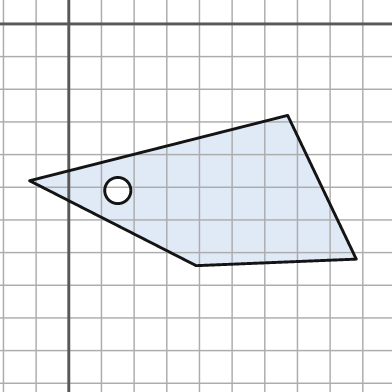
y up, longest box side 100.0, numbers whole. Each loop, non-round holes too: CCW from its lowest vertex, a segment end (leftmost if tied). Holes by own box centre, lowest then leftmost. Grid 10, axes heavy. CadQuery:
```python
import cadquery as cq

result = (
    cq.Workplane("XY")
    .moveTo(39.0, -74.0)
    .lineTo(88.0, -72.0)
    .lineTo(67.0, -28.0)
    .lineTo(-12.0, -48.0)
    .close()
    .moveTo(15.0, -51.0)
    .circle(4.0)
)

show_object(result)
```